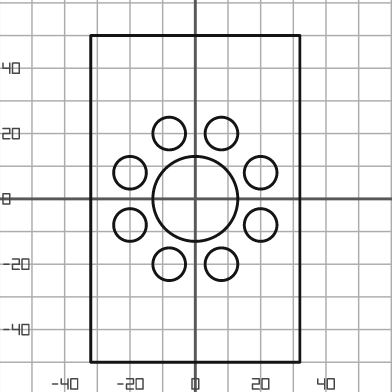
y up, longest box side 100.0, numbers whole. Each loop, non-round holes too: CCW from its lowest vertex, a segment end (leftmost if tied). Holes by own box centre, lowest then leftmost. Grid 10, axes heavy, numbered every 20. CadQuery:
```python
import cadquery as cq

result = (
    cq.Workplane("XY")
    .moveTo(-32.0, -50.0)
    .lineTo(32.0, -50.0)
    .lineTo(32.0, 50.0)
    .lineTo(-32.0, 50.0)
    .close()
    .moveTo(-8.0, -20.0)
    .circle(5.0)
    .moveTo(8.0, -20.0)
    .circle(5.0)
    .moveTo(-20.0, -8.0)
    .circle(5.0)
    .moveTo(20.0, -8.0)
    .circle(5.0)
    .moveTo(0.0, 0.0)
    .circle(13.0)
    .moveTo(-20.0, 8.0)
    .circle(5.0)
    .moveTo(20.0, 8.0)
    .circle(5.0)
    .moveTo(-8.0, 20.0)
    .circle(5.0)
    .moveTo(8.0, 20.0)
    .circle(5.0)
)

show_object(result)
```